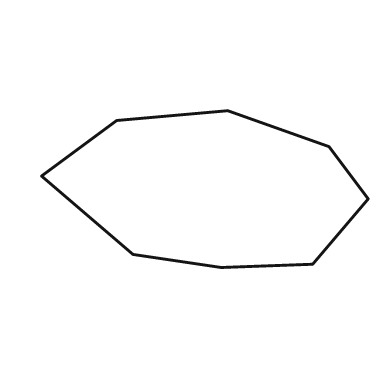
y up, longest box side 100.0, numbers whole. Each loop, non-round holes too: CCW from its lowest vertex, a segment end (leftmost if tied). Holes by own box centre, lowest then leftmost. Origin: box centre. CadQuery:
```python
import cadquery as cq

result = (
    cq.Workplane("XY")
    .moveTo(5.0, -24.0)
    .lineTo(33.0, -23.0)
    .lineTo(50.0, -3.0)
    .lineTo(38.0, 13.0)
    .lineTo(7.0, 24.0)
    .lineTo(-27.0, 21.0)
    .lineTo(-50.0, 4.0)
    .lineTo(-22.0, -20.0)
    .close()
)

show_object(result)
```